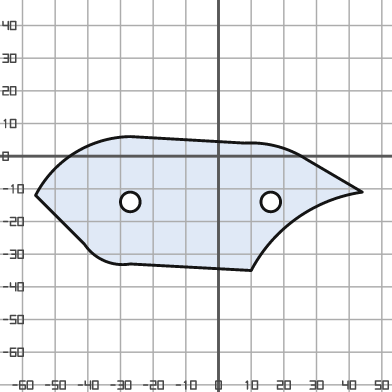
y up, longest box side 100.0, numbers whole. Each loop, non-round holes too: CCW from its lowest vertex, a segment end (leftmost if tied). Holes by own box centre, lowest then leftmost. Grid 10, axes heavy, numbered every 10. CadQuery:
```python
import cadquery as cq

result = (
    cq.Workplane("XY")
    .moveTo(10.0, -35.0)
    .threePointArc((24.0, -19.0), (44.0, -11.0))
    .lineTo(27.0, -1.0)
    .threePointArc((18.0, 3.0), (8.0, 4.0))
    .lineTo(-27.0, 6.0)
    .threePointArc((-44.0, 1.0), (-56.0, -12.0))
    .lineTo(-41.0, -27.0)
    .threePointArc((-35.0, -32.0), (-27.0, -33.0))
    .close()
    .moveTo(-27.0, -14.0)
    .circle(3.0)
    .moveTo(16.0, -14.0)
    .circle(3.0)
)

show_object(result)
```